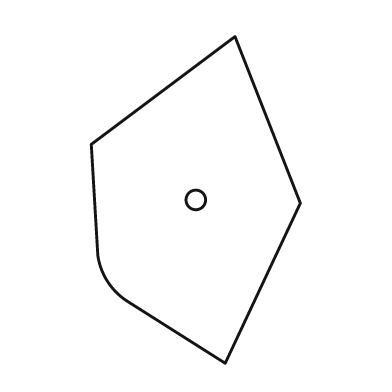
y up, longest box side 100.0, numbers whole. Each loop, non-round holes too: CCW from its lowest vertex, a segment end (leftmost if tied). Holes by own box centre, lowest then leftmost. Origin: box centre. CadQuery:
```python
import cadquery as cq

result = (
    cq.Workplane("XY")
    .moveTo(9.0, -50.0)
    .lineTo(32.0, -1.0)
    .lineTo(12.0, 50.0)
    .lineTo(-32.0, 17.0)
    .lineTo(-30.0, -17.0)
    .threePointArc((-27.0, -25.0), (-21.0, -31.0))
    .close()
    .moveTo(0.0, 0.0)
    .circle(3.0)
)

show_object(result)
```